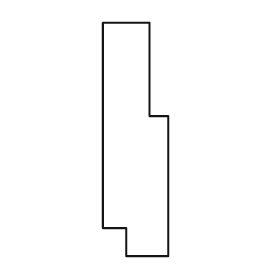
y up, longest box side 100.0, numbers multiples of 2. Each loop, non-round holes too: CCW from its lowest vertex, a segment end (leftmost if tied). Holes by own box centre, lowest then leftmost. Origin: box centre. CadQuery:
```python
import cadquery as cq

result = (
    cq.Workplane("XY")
    .moveTo(-4.0, -50.0)
    .lineTo(14.0, -50.0)
    .lineTo(14.0, 10.0)
    .lineTo(6.0, 10.0)
    .lineTo(6.0, 50.0)
    .lineTo(-14.0, 50.0)
    .lineTo(-14.0, -38.0)
    .lineTo(-4.0, -38.0)
    .close()
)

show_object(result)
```